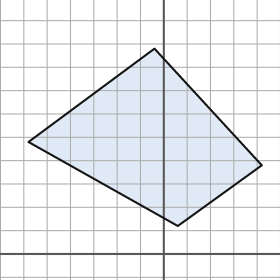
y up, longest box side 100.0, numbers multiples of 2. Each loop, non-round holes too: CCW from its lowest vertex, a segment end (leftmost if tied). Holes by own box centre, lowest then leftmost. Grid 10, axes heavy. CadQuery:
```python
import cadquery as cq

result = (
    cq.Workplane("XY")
    .moveTo(6.0, 12.0)
    .lineTo(42.0, 38.0)
    .lineTo(-4.0, 88.0)
    .lineTo(-58.0, 48.0)
    .close()
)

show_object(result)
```